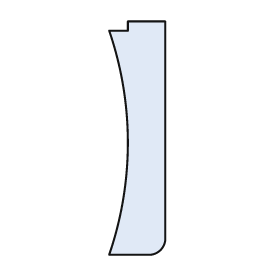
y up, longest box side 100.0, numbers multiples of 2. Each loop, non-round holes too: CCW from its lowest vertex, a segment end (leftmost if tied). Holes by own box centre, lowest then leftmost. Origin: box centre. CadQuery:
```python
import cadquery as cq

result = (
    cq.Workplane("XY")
    .moveTo(-12.0, -50.0)
    .lineTo(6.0, -50.0)
    .threePointArc((10.0, -48.0), (12.0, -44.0))
    .lineTo(12.0, 50.0)
    .lineTo(-4.0, 50.0)
    .lineTo(-4.0, 46.0)
    .lineTo(-12.0, 46.0)
    .threePointArc((-4.0, -2.0), (-12.0, -50.0))
    .close()
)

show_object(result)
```